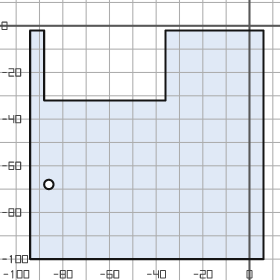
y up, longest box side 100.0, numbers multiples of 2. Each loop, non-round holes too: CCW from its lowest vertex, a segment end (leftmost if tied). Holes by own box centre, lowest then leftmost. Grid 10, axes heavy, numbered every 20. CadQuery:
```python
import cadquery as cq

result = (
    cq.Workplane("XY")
    .moveTo(-94.0, -100.0)
    .lineTo(6.0, -100.0)
    .lineTo(6.0, -2.0)
    .lineTo(-36.0, -2.0)
    .lineTo(-36.0, -32.0)
    .lineTo(-88.0, -32.0)
    .lineTo(-88.0, -2.0)
    .lineTo(-94.0, -2.0)
    .close()
    .moveTo(-86.0, -68.0)
    .circle(2.0)
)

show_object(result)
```